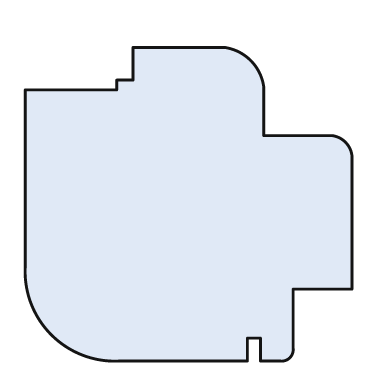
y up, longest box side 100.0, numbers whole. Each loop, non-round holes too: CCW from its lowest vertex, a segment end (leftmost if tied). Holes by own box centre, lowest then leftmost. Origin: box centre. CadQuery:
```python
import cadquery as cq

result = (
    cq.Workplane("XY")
    .moveTo(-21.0, -48.0)
    .lineTo(18.0, -48.0)
    .lineTo(18.0, -41.0)
    .lineTo(22.0, -41.0)
    .lineTo(22.0, -48.0)
    .lineTo(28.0, -48.0)
    .threePointArc((31.0, -47.0), (32.0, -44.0))
    .lineTo(32.0, -26.0)
    .lineTo(50.0, -26.0)
    .lineTo(50.0, 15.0)
    .threePointArc((48.0, 19.0), (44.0, 21.0))
    .lineTo(23.0, 21.0)
    .lineTo(23.0, 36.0)
    .threePointArc((19.0, 44.0), (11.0, 48.0))
    .lineTo(-17.0, 48.0)
    .lineTo(-17.0, 38.0)
    .lineTo(-22.0, 38.0)
    .lineTo(-22.0, 35.0)
    .lineTo(-50.0, 35.0)
    .lineTo(-50.0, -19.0)
    .threePointArc((-42.0, -40.0), (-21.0, -48.0))
    .close()
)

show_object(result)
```